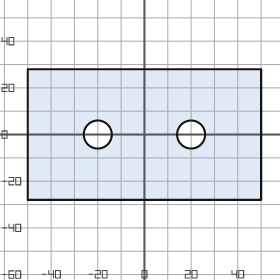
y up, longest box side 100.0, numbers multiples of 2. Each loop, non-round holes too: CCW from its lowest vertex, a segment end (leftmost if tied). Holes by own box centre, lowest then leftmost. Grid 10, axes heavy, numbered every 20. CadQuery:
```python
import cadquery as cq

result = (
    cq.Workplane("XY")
    .moveTo(-50.0, -28.0)
    .lineTo(50.0, -28.0)
    .lineTo(50.0, 28.0)
    .lineTo(-50.0, 28.0)
    .close()
    .moveTo(-20.0, 0.0)
    .circle(6.0)
    .moveTo(20.0, 0.0)
    .circle(6.0)
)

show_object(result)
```